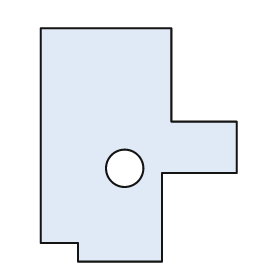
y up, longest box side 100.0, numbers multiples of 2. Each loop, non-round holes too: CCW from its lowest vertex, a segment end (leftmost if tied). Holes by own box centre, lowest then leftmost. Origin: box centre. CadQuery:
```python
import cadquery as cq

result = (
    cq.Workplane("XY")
    .moveTo(-26.0, -50.0)
    .lineTo(10.0, -50.0)
    .lineTo(10.0, -12.0)
    .lineTo(42.0, -12.0)
    .lineTo(42.0, 10.0)
    .lineTo(14.0, 10.0)
    .lineTo(14.0, 50.0)
    .lineTo(-42.0, 50.0)
    .lineTo(-42.0, -42.0)
    .lineTo(-26.0, -42.0)
    .close()
    .moveTo(-6.0, -10.0)
    .circle(8.0)
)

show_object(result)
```